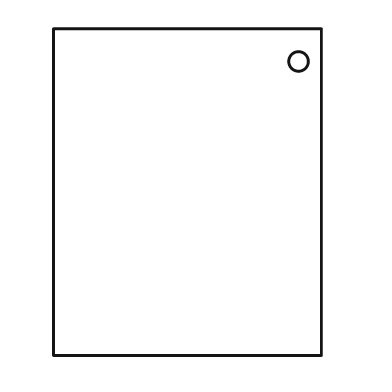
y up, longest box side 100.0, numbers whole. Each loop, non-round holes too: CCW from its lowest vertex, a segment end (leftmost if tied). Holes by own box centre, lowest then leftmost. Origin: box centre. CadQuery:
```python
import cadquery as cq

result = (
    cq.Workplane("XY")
    .moveTo(-41.0, -50.0)
    .lineTo(41.0, -50.0)
    .lineTo(41.0, 50.0)
    .lineTo(-41.0, 50.0)
    .close()
    .moveTo(34.0, 40.0)
    .circle(3.0)
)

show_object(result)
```